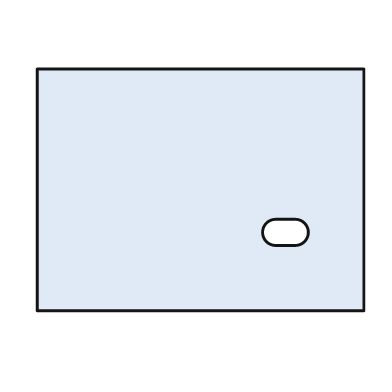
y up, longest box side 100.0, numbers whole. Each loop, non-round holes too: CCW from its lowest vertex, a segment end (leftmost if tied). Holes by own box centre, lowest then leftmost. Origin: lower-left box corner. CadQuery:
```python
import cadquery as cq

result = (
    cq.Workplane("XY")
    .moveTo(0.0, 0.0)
    .lineTo(100.0, 0.0)
    .lineTo(100.0, 74.0)
    .lineTo(0.0, 74.0)
    .close()
    .moveTo(73.0, 20.0)
    .lineTo(79.0, 20.0)
    .threePointArc((83.0, 24.0), (79.0, 28.0))
    .lineTo(73.0, 28.0)
    .threePointArc((69.0, 24.0), (73.0, 20.0))
    .close()
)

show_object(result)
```